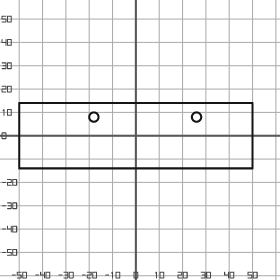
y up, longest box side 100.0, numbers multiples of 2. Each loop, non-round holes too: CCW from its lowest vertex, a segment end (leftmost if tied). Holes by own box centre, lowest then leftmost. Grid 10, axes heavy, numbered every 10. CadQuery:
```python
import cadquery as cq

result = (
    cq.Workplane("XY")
    .moveTo(-50.0, -14.0)
    .lineTo(50.0, -14.0)
    .lineTo(50.0, 14.0)
    .lineTo(-50.0, 14.0)
    .close()
    .moveTo(-18.0, 8.0)
    .circle(2.0)
    .moveTo(26.0, 8.0)
    .circle(2.0)
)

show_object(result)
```